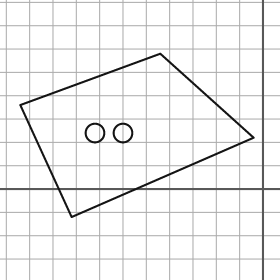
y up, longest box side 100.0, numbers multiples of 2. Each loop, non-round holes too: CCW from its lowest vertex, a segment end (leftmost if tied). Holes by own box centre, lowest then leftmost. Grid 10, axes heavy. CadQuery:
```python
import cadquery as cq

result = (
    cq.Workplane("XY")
    .moveTo(-82.0, -12.0)
    .lineTo(-4.0, 22.0)
    .lineTo(-44.0, 58.0)
    .lineTo(-104.0, 36.0)
    .close()
    .moveTo(-72.0, 24.0)
    .circle(4.0)
    .moveTo(-60.0, 24.0)
    .circle(4.0)
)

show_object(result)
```